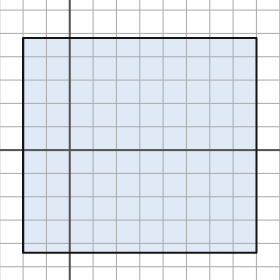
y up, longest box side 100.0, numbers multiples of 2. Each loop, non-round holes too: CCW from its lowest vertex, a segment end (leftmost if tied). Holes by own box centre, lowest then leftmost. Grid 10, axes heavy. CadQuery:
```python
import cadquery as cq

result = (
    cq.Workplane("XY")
    .moveTo(-20.0, -44.0)
    .lineTo(80.0, -44.0)
    .lineTo(80.0, 48.0)
    .lineTo(-20.0, 48.0)
    .close()
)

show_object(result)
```